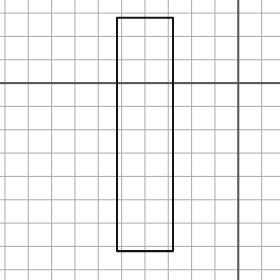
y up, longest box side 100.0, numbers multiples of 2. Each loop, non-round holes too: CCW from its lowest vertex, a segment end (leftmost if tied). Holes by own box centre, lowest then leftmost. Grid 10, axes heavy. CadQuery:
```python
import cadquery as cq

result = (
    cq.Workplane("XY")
    .moveTo(-52.0, -72.0)
    .lineTo(-28.0, -72.0)
    .lineTo(-28.0, 28.0)
    .lineTo(-52.0, 28.0)
    .close()
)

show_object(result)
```